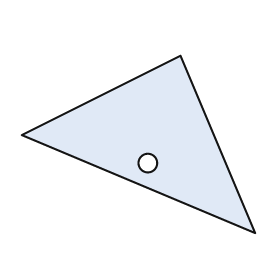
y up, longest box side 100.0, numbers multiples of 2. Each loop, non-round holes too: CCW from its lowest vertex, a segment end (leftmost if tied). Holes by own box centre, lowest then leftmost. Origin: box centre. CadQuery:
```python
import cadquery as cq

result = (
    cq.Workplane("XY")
    .moveTo(50.0, -38.0)
    .lineTo(18.0, 38.0)
    .lineTo(-50.0, 4.0)
    .close()
    .moveTo(4.0, -8.0)
    .circle(4.0)
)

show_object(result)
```